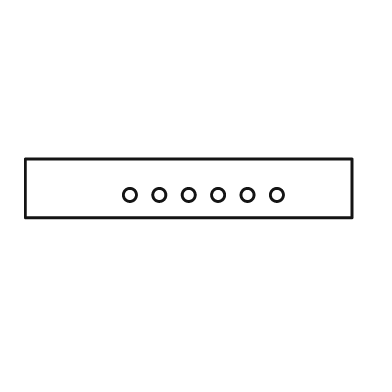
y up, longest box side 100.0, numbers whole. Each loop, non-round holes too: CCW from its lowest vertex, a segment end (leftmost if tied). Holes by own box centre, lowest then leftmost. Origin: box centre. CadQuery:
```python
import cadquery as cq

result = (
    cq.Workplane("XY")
    .moveTo(-50.0, -9.0)
    .lineTo(50.0, -9.0)
    .lineTo(50.0, 9.0)
    .lineTo(-50.0, 9.0)
    .close()
    .moveTo(-18.0, -2.0)
    .circle(2.0)
    .moveTo(-9.0, -2.0)
    .circle(2.0)
    .moveTo(0.0, -2.0)
    .circle(2.0)
    .moveTo(9.0, -2.0)
    .circle(2.0)
    .moveTo(18.0, -2.0)
    .circle(2.0)
    .moveTo(27.0, -2.0)
    .circle(2.0)
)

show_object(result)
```